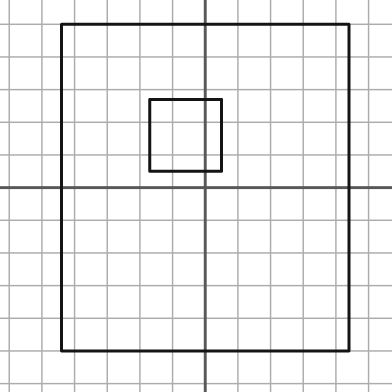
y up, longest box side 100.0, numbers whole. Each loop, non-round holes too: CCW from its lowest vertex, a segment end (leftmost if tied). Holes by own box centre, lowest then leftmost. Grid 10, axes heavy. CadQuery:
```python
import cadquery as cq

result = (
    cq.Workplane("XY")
    .moveTo(-44.0, -50.0)
    .lineTo(44.0, -50.0)
    .lineTo(44.0, 50.0)
    .lineTo(-44.0, 50.0)
    .close()
    .moveTo(-17.0, 5.0)
    .lineTo(5.0, 5.0)
    .lineTo(5.0, 27.0)
    .lineTo(-17.0, 27.0)
    .close()
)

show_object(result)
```